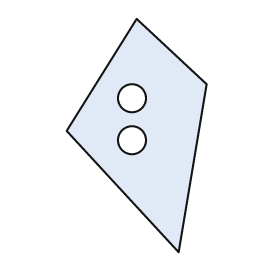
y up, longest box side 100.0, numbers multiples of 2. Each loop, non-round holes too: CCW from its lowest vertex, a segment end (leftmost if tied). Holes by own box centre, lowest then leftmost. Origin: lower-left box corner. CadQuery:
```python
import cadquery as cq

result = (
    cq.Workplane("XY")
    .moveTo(48.0, 0.0)
    .lineTo(60.0, 72.0)
    .lineTo(30.0, 100.0)
    .lineTo(0.0, 52.0)
    .close()
    .moveTo(28.0, 48.0)
    .circle(6.0)
    .moveTo(28.0, 66.0)
    .circle(6.0)
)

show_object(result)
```